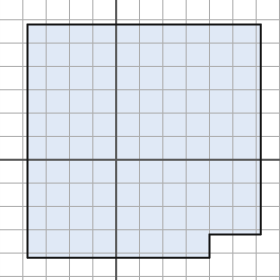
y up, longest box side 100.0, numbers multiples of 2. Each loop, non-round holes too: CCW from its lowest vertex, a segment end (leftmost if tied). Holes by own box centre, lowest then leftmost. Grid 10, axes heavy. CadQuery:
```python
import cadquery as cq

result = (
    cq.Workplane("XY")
    .moveTo(-38.0, -42.0)
    .lineTo(40.0, -42.0)
    .lineTo(40.0, -32.0)
    .lineTo(62.0, -32.0)
    .lineTo(62.0, 58.0)
    .lineTo(-38.0, 58.0)
    .close()
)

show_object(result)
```